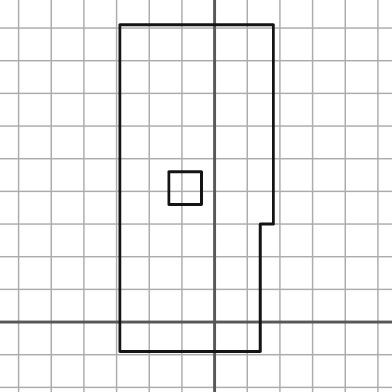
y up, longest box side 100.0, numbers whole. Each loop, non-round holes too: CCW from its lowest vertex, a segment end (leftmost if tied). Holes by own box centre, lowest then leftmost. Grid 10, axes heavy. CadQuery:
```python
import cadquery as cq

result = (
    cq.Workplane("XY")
    .moveTo(-29.0, -9.0)
    .lineTo(14.0, -9.0)
    .lineTo(14.0, 30.0)
    .lineTo(18.0, 30.0)
    .lineTo(18.0, 91.0)
    .lineTo(-29.0, 91.0)
    .close()
    .moveTo(-14.0, 36.0)
    .lineTo(-4.0, 36.0)
    .lineTo(-4.0, 46.0)
    .lineTo(-14.0, 46.0)
    .close()
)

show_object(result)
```